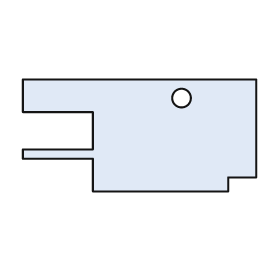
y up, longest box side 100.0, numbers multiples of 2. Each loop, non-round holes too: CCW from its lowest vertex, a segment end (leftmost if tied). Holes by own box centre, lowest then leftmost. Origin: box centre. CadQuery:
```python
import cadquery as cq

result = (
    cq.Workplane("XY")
    .moveTo(-20.0, -24.0)
    .lineTo(38.0, -24.0)
    .lineTo(38.0, -18.0)
    .lineTo(50.0, -18.0)
    .lineTo(50.0, 24.0)
    .lineTo(-50.0, 24.0)
    .lineTo(-50.0, 10.0)
    .lineTo(-20.0, 10.0)
    .lineTo(-20.0, -6.0)
    .lineTo(-50.0, -6.0)
    .lineTo(-50.0, -10.0)
    .lineTo(-20.0, -10.0)
    .close()
    .moveTo(18.0, 16.0)
    .circle(4.0)
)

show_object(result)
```